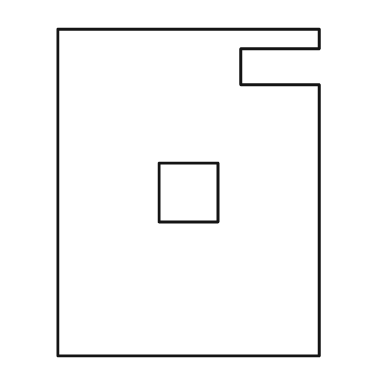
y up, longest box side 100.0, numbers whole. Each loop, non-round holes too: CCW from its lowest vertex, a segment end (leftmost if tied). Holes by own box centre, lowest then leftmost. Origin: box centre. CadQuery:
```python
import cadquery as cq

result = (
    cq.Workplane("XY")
    .moveTo(-40.0, -50.0)
    .lineTo(40.0, -50.0)
    .lineTo(40.0, 33.0)
    .lineTo(16.0, 33.0)
    .lineTo(16.0, 44.0)
    .lineTo(40.0, 44.0)
    .lineTo(40.0, 50.0)
    .lineTo(-40.0, 50.0)
    .close()
    .moveTo(-9.0, -9.0)
    .lineTo(9.0, -9.0)
    .lineTo(9.0, 9.0)
    .lineTo(-9.0, 9.0)
    .close()
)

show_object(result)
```